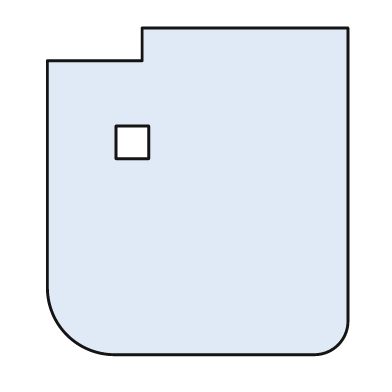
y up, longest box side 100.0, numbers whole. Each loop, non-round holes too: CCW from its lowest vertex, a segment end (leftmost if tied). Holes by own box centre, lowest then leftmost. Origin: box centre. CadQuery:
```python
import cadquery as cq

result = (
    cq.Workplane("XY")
    .moveTo(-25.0, -50.0)
    .lineTo(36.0, -50.0)
    .threePointArc((43.0, -47.0), (46.0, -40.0))
    .lineTo(46.0, 50.0)
    .lineTo(-17.0, 50.0)
    .lineTo(-17.0, 40.0)
    .lineTo(-46.0, 40.0)
    .lineTo(-46.0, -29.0)
    .threePointArc((-40.0, -44.0), (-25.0, -50.0))
    .close()
    .moveTo(-25.0, 10.0)
    .lineTo(-15.0, 10.0)
    .lineTo(-15.0, 20.0)
    .lineTo(-25.0, 20.0)
    .close()
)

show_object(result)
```